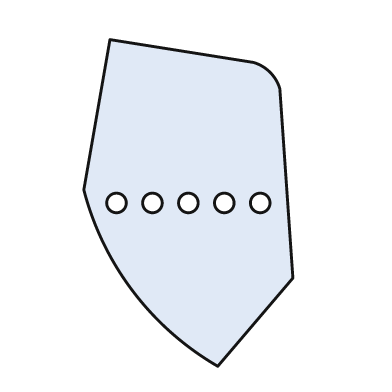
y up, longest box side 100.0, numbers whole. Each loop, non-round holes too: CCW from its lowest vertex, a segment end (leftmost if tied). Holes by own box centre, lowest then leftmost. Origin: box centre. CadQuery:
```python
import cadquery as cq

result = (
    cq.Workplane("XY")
    .moveTo(9.0, -50.0)
    .lineTo(32.0, -23.0)
    .lineTo(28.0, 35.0)
    .threePointArc((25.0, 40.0), (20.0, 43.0))
    .lineTo(-24.0, 50.0)
    .lineTo(-32.0, 4.0)
    .threePointArc((-17.0, -27.0), (9.0, -50.0))
    .close()
    .moveTo(-22.0, 0.0)
    .circle(3.0)
    .moveTo(-11.0, 0.0)
    .circle(3.0)
    .moveTo(0.0, 0.0)
    .circle(3.0)
    .moveTo(11.0, 0.0)
    .circle(3.0)
    .moveTo(22.0, 0.0)
    .circle(3.0)
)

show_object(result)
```